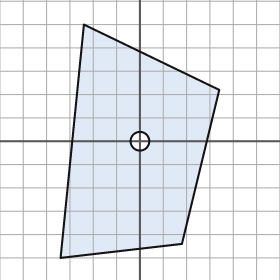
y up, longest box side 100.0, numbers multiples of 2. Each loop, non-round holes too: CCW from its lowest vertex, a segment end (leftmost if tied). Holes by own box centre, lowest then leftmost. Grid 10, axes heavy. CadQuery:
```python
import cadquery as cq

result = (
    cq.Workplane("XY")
    .moveTo(-34.0, -50.0)
    .lineTo(18.0, -44.0)
    .lineTo(34.0, 22.0)
    .lineTo(-24.0, 50.0)
    .close()
    .moveTo(0.0, 0.0)
    .circle(4.0)
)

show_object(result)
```